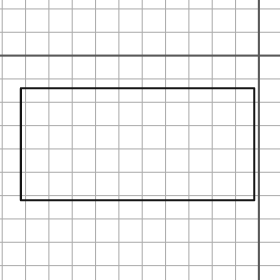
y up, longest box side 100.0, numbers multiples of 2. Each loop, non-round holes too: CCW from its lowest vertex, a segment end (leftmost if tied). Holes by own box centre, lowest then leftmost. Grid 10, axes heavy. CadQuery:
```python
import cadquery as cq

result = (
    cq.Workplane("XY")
    .moveTo(-102.0, -62.0)
    .lineTo(-2.0, -62.0)
    .lineTo(-2.0, -14.0)
    .lineTo(-102.0, -14.0)
    .close()
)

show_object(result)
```